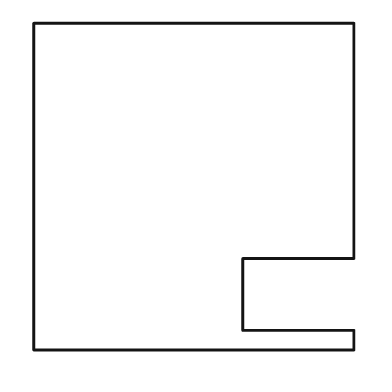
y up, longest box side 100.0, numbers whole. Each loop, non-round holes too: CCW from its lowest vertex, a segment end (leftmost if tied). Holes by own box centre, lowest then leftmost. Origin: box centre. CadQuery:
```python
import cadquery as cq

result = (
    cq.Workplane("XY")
    .moveTo(-49.0, -50.0)
    .lineTo(49.0, -50.0)
    .lineTo(49.0, -44.0)
    .lineTo(15.0, -44.0)
    .lineTo(15.0, -22.0)
    .lineTo(49.0, -22.0)
    .lineTo(49.0, 50.0)
    .lineTo(-49.0, 50.0)
    .close()
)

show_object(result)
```